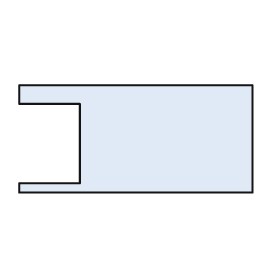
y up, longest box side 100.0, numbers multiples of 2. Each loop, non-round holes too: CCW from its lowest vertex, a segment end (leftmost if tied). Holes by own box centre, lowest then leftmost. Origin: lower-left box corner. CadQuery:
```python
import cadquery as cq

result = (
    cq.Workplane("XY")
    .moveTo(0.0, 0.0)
    .lineTo(100.0, 0.0)
    .lineTo(100.0, 46.0)
    .lineTo(0.0, 46.0)
    .lineTo(0.0, 38.0)
    .lineTo(26.0, 38.0)
    .lineTo(26.0, 4.0)
    .lineTo(0.0, 4.0)
    .close()
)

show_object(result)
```